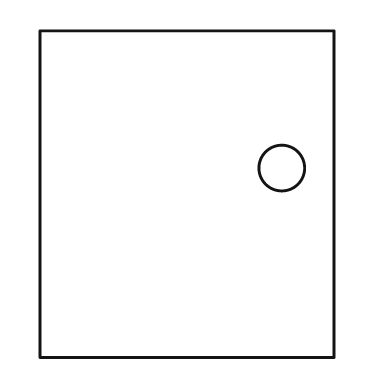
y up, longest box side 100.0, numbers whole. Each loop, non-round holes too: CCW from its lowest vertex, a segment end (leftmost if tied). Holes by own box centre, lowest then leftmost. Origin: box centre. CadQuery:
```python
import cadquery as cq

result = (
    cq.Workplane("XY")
    .moveTo(-45.0, -50.0)
    .lineTo(45.0, -50.0)
    .lineTo(45.0, 50.0)
    .lineTo(-45.0, 50.0)
    .close()
    .moveTo(29.0, 8.0)
    .circle(7.0)
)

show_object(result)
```